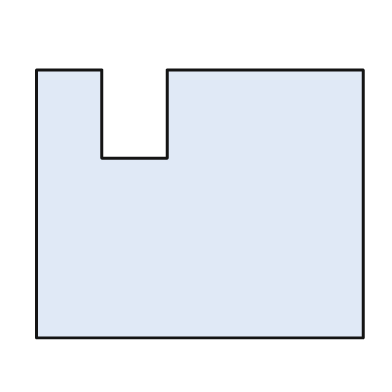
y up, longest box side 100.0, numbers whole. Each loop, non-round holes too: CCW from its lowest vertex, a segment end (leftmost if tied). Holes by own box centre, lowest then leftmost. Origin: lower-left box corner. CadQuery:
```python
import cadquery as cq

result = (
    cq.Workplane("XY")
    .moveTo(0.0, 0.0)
    .lineTo(100.0, 0.0)
    .lineTo(100.0, 82.0)
    .lineTo(40.0, 82.0)
    .lineTo(40.0, 55.0)
    .lineTo(20.0, 55.0)
    .lineTo(20.0, 82.0)
    .lineTo(0.0, 82.0)
    .close()
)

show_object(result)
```